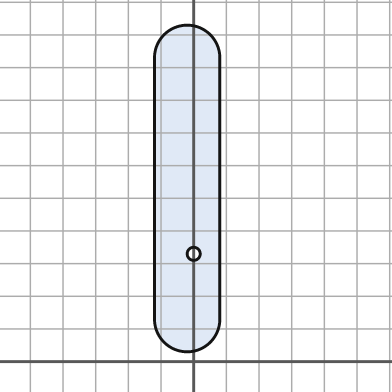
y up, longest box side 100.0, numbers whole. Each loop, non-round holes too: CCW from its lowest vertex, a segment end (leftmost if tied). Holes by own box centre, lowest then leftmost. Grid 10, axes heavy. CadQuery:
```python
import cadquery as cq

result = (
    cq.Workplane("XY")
    .moveTo(-12.0, 13.0)
    .threePointArc((-2.0, 3.0), (8.0, 13.0))
    .lineTo(8.0, 93.0)
    .threePointArc((-2.0, 103.0), (-12.0, 93.0))
    .close()
    .moveTo(0.0, 33.0)
    .circle(2.0)
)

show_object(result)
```